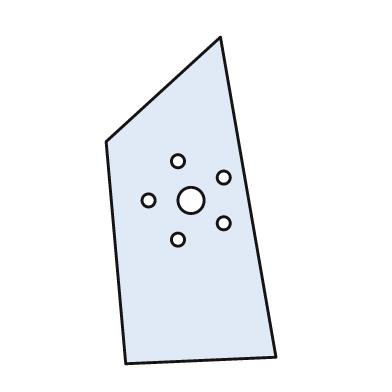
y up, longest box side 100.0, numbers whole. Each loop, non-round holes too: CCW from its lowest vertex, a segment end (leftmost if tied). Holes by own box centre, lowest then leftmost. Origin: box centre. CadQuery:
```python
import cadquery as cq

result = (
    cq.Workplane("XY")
    .moveTo(-20.0, -50.0)
    .lineTo(26.0, -48.0)
    .lineTo(9.0, 50.0)
    .lineTo(-26.0, 18.0)
    .close()
    .moveTo(-4.0, -12.0)
    .circle(2.0)
    .moveTo(10.0, -7.0)
    .circle(2.0)
    .moveTo(-13.0, 0.0)
    .circle(2.0)
    .moveTo(0.0, 0.0)
    .circle(4.0)
    .moveTo(10.0, 7.0)
    .circle(2.0)
    .moveTo(-4.0, 12.0)
    .circle(2.0)
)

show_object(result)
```